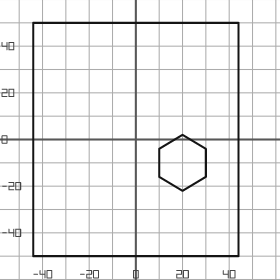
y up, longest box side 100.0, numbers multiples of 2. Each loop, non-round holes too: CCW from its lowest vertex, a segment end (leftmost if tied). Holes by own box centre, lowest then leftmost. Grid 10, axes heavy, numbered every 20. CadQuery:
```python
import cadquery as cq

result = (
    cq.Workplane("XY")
    .moveTo(-44.0, -50.0)
    .lineTo(44.0, -50.0)
    .lineTo(44.0, 50.0)
    .lineTo(-44.0, 50.0)
    .close()
    .moveTo(20.0, -22.0)
    .lineTo(30.0, -16.0)
    .lineTo(30.0, -4.0)
    .lineTo(20.0, 2.0)
    .lineTo(10.0, -4.0)
    .lineTo(10.0, -16.0)
    .close()
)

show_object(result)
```